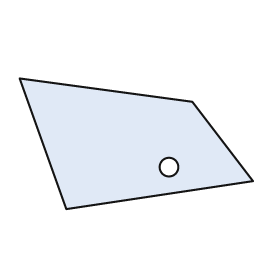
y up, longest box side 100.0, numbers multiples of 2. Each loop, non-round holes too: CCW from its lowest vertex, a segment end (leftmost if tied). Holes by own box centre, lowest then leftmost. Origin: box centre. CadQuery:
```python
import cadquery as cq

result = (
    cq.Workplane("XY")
    .moveTo(-30.0, -28.0)
    .lineTo(50.0, -16.0)
    .lineTo(24.0, 18.0)
    .lineTo(-50.0, 28.0)
    .close()
    .moveTo(14.0, -10.0)
    .circle(4.0)
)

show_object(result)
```